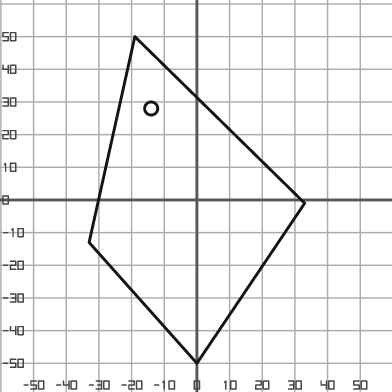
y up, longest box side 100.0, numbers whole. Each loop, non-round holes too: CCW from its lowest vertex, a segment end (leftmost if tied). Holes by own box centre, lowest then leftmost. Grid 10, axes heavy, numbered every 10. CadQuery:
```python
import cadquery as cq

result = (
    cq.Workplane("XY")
    .moveTo(0.0, -50.0)
    .lineTo(33.0, -1.0)
    .lineTo(-19.0, 50.0)
    .lineTo(-33.0, -13.0)
    .close()
    .moveTo(-14.0, 28.0)
    .circle(2.0)
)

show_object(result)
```